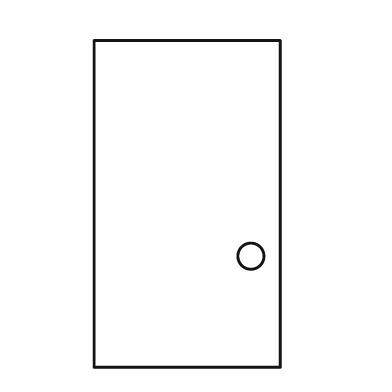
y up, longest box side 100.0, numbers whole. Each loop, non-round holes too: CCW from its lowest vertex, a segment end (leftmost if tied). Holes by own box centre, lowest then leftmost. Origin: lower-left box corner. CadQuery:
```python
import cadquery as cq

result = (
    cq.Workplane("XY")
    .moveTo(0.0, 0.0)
    .lineTo(57.0, 0.0)
    .lineTo(57.0, 100.0)
    .lineTo(0.0, 100.0)
    .close()
    .moveTo(48.0, 34.0)
    .circle(4.0)
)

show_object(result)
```